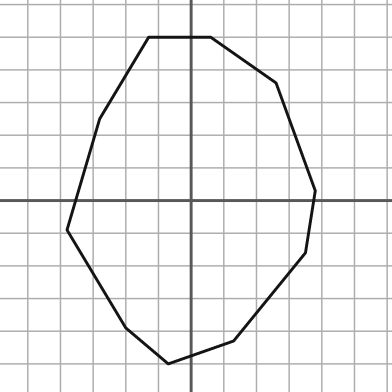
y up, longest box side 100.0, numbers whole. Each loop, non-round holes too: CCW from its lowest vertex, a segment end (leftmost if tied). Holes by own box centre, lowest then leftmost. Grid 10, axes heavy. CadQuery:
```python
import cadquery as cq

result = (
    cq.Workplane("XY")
    .moveTo(-7.0, -50.0)
    .lineTo(13.0, -43.0)
    .lineTo(35.0, -16.0)
    .lineTo(38.0, 3.0)
    .lineTo(26.0, 36.0)
    .lineTo(6.0, 50.0)
    .lineTo(-13.0, 50.0)
    .lineTo(-28.0, 25.0)
    .lineTo(-38.0, -9.0)
    .lineTo(-20.0, -39.0)
    .close()
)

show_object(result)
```